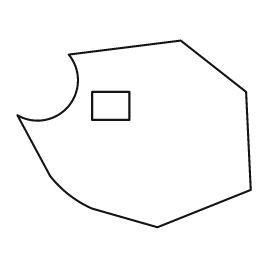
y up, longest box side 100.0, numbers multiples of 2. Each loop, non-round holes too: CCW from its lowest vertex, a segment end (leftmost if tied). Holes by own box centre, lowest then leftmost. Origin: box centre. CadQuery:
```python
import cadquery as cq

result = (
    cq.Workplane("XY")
    .moveTo(10.0, -40.0)
    .lineTo(50.0, -24.0)
    .lineTo(48.0, 18.0)
    .lineTo(20.0, 40.0)
    .lineTo(-28.0, 34.0)
    .threePointArc((-28.0, 12.0), (-50.0, 8.0))
    .lineTo(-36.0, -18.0)
    .threePointArc((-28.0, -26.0), (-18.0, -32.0))
    .close()
    .moveTo(-18.0, 6.0)
    .lineTo(-2.0, 6.0)
    .lineTo(-2.0, 18.0)
    .lineTo(-18.0, 18.0)
    .close()
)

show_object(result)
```